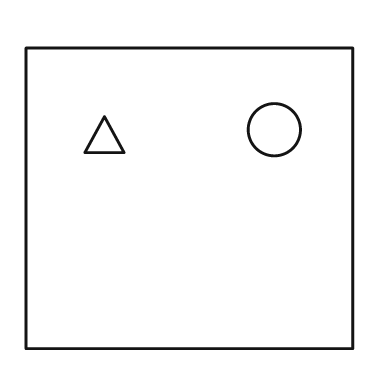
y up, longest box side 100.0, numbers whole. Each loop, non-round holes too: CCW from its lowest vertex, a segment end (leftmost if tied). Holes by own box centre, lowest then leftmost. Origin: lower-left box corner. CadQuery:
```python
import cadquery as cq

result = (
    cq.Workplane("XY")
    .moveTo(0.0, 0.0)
    .lineTo(100.0, 0.0)
    .lineTo(100.0, 92.0)
    .lineTo(0.0, 92.0)
    .close()
    .moveTo(18.0, 60.0)
    .lineTo(30.0, 60.0)
    .lineTo(24.0, 71.0)
    .close()
    .moveTo(76.0, 67.0)
    .circle(8.0)
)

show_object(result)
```